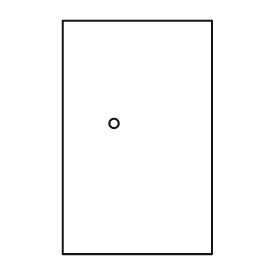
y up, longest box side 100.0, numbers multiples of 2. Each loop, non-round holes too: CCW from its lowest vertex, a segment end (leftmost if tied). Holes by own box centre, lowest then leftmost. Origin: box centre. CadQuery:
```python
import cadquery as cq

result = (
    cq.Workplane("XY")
    .moveTo(-32.0, -50.0)
    .lineTo(32.0, -50.0)
    .lineTo(32.0, 50.0)
    .lineTo(-32.0, 50.0)
    .close()
    .moveTo(-10.0, 6.0)
    .circle(2.0)
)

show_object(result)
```